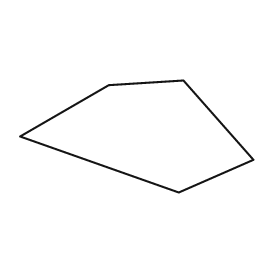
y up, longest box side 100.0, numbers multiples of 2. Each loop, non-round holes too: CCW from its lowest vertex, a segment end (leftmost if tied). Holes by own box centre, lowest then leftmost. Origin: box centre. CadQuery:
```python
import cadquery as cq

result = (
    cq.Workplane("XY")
    .moveTo(18.0, -24.0)
    .lineTo(50.0, -10.0)
    .lineTo(20.0, 24.0)
    .lineTo(-12.0, 22.0)
    .lineTo(-50.0, 0.0)
    .close()
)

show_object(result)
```